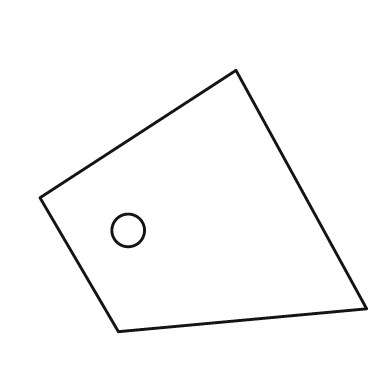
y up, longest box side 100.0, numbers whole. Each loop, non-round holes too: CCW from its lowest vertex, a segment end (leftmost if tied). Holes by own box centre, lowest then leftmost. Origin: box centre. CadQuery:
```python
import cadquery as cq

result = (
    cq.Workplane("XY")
    .moveTo(-26.0, -40.0)
    .lineTo(50.0, -33.0)
    .lineTo(10.0, 40.0)
    .lineTo(-50.0, 1.0)
    .close()
    .moveTo(-23.0, -9.0)
    .circle(5.0)
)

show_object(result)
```